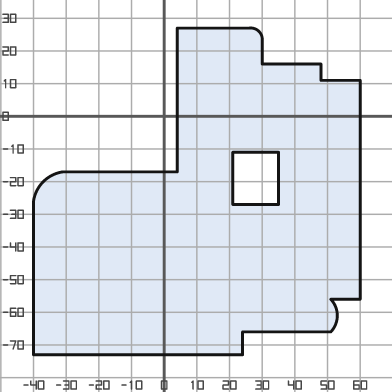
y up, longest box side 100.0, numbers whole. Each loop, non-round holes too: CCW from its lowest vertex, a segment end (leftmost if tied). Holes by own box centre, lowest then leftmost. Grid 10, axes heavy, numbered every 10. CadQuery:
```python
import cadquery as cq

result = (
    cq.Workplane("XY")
    .moveTo(-40.0, -73.0)
    .lineTo(24.0, -73.0)
    .lineTo(24.0, -66.0)
    .lineTo(51.0, -66.0)
    .threePointArc((53.0, -61.0), (51.0, -56.0))
    .lineTo(60.0, -56.0)
    .lineTo(60.0, 11.0)
    .lineTo(48.0, 11.0)
    .lineTo(48.0, 16.0)
    .lineTo(30.0, 16.0)
    .lineTo(30.0, 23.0)
    .threePointArc((29.0, 26.0), (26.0, 27.0))
    .lineTo(4.0, 27.0)
    .lineTo(4.0, -17.0)
    .lineTo(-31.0, -17.0)
    .threePointArc((-37.0, -20.0), (-40.0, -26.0))
    .close()
    .moveTo(21.0, -27.0)
    .lineTo(35.0, -27.0)
    .lineTo(35.0, -11.0)
    .lineTo(21.0, -11.0)
    .close()
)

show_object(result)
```